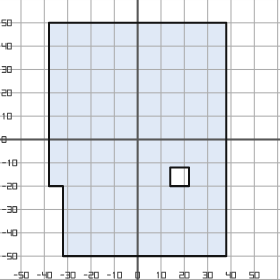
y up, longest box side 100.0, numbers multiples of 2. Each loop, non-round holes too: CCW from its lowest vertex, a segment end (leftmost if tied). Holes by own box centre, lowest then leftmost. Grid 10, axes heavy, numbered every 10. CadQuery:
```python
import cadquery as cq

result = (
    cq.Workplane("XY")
    .moveTo(-32.0, -50.0)
    .lineTo(38.0, -50.0)
    .lineTo(38.0, 50.0)
    .lineTo(-38.0, 50.0)
    .lineTo(-38.0, -20.0)
    .lineTo(-32.0, -20.0)
    .close()
    .moveTo(14.0, -20.0)
    .lineTo(22.0, -20.0)
    .lineTo(22.0, -12.0)
    .lineTo(14.0, -12.0)
    .close()
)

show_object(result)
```